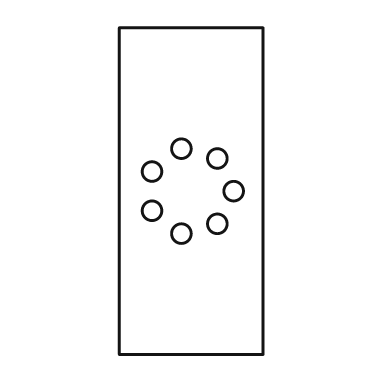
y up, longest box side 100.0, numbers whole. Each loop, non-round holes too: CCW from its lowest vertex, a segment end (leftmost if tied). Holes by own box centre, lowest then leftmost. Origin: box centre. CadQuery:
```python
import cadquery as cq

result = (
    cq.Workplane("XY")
    .moveTo(-22.0, -50.0)
    .lineTo(22.0, -50.0)
    .lineTo(22.0, 50.0)
    .lineTo(-22.0, 50.0)
    .close()
    .moveTo(-3.0, -13.0)
    .circle(3.0)
    .moveTo(8.0, -10.0)
    .circle(3.0)
    .moveTo(-12.0, -6.0)
    .circle(3.0)
    .moveTo(13.0, 0.0)
    .circle(3.0)
    .moveTo(-12.0, 6.0)
    .circle(3.0)
    .moveTo(8.0, 10.0)
    .circle(3.0)
    .moveTo(-3.0, 13.0)
    .circle(3.0)
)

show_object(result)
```